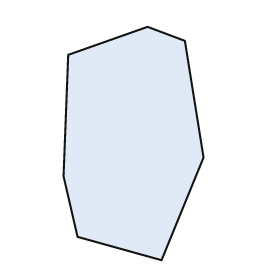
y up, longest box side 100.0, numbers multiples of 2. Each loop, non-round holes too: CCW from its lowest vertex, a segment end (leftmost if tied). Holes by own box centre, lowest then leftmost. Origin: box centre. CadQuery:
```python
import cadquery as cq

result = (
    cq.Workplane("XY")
    .moveTo(12.0, -50.0)
    .lineTo(30.0, -6.0)
    .lineTo(22.0, 44.0)
    .lineTo(6.0, 50.0)
    .lineTo(-28.0, 38.0)
    .lineTo(-30.0, -14.0)
    .lineTo(-24.0, -40.0)
    .close()
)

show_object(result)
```